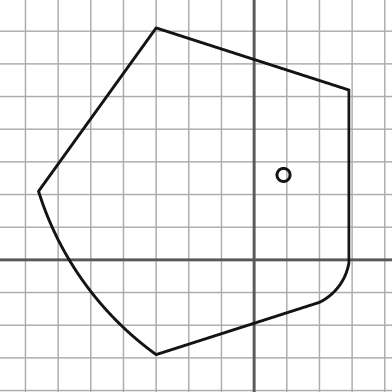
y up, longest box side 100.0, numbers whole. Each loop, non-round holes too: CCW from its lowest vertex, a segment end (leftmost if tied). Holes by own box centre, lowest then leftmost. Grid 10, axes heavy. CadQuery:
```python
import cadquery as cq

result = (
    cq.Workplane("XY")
    .moveTo(-30.0, -29.0)
    .lineTo(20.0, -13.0)
    .threePointArc((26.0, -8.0), (29.0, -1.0))
    .lineTo(29.0, 52.0)
    .lineTo(-30.0, 71.0)
    .lineTo(-66.0, 21.0)
    .threePointArc((-52.0, -7.0), (-30.0, -29.0))
    .close()
    .moveTo(9.0, 26.0)
    .circle(2.0)
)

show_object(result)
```